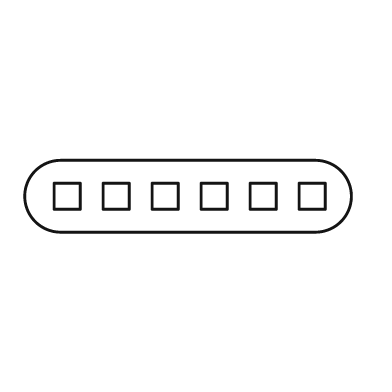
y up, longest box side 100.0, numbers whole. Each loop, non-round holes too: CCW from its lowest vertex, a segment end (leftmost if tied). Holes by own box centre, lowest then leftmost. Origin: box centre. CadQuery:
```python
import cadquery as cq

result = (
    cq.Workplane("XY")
    .moveTo(-39.0, -11.0)
    .lineTo(39.0, -11.0)
    .threePointArc((50.0, 0.0), (39.0, 11.0))
    .lineTo(-39.0, 11.0)
    .threePointArc((-50.0, 0.0), (-39.0, -11.0))
    .close()
    .moveTo(-41.0, -4.0)
    .lineTo(-33.0, -4.0)
    .lineTo(-33.0, 4.0)
    .lineTo(-41.0, 4.0)
    .close()
    .moveTo(-26.0, -4.0)
    .lineTo(-18.0, -4.0)
    .lineTo(-18.0, 4.0)
    .lineTo(-26.0, 4.0)
    .close()
    .moveTo(-11.0, -4.0)
    .lineTo(-3.0, -4.0)
    .lineTo(-3.0, 4.0)
    .lineTo(-11.0, 4.0)
    .close()
    .moveTo(4.0, -4.0)
    .lineTo(12.0, -4.0)
    .lineTo(12.0, 4.0)
    .lineTo(4.0, 4.0)
    .close()
    .moveTo(19.0, -4.0)
    .lineTo(27.0, -4.0)
    .lineTo(27.0, 4.0)
    .lineTo(19.0, 4.0)
    .close()
    .moveTo(34.0, -4.0)
    .lineTo(42.0, -4.0)
    .lineTo(42.0, 4.0)
    .lineTo(34.0, 4.0)
    .close()
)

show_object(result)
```